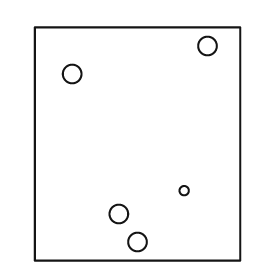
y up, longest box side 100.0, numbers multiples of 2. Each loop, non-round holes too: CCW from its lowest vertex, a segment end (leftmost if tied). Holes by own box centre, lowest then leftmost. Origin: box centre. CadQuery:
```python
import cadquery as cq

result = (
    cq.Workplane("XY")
    .moveTo(-44.0, -50.0)
    .lineTo(44.0, -50.0)
    .lineTo(44.0, 50.0)
    .lineTo(-44.0, 50.0)
    .close()
    .moveTo(0.0, -42.0)
    .circle(4.0)
    .moveTo(-8.0, -30.0)
    .circle(4.0)
    .moveTo(20.0, -20.0)
    .circle(2.0)
    .moveTo(-28.0, 30.0)
    .circle(4.0)
    .moveTo(30.0, 42.0)
    .circle(4.0)
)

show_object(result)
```